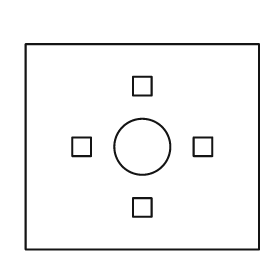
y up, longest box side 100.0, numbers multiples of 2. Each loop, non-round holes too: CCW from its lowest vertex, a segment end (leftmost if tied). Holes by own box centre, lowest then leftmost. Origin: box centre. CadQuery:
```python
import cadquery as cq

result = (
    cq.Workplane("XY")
    .moveTo(-50.0, -44.0)
    .lineTo(50.0, -44.0)
    .lineTo(50.0, 44.0)
    .lineTo(-50.0, 44.0)
    .close()
    .moveTo(-4.0, -30.0)
    .lineTo(4.0, -30.0)
    .lineTo(4.0, -22.0)
    .lineTo(-4.0, -22.0)
    .close()
    .moveTo(-30.0, -4.0)
    .lineTo(-22.0, -4.0)
    .lineTo(-22.0, 4.0)
    .lineTo(-30.0, 4.0)
    .close()
    .moveTo(0.0, 0.0)
    .circle(12.0)
    .moveTo(22.0, -4.0)
    .lineTo(30.0, -4.0)
    .lineTo(30.0, 4.0)
    .lineTo(22.0, 4.0)
    .close()
    .moveTo(-4.0, 22.0)
    .lineTo(4.0, 22.0)
    .lineTo(4.0, 30.0)
    .lineTo(-4.0, 30.0)
    .close()
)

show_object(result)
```